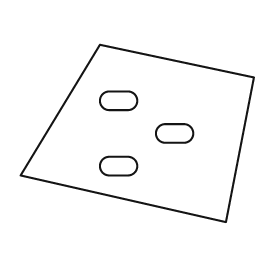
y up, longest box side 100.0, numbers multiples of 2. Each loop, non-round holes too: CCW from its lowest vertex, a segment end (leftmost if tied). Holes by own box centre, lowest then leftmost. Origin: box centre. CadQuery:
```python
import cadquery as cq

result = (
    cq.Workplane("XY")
    .moveTo(38.0, -38.0)
    .lineTo(50.0, 24.0)
    .lineTo(-16.0, 38.0)
    .lineTo(-50.0, -18.0)
    .close()
    .moveTo(-12.0, -18.0)
    .lineTo(-4.0, -18.0)
    .threePointArc((0.0, -14.0), (-4.0, -10.0))
    .lineTo(-12.0, -10.0)
    .threePointArc((-16.0, -14.0), (-12.0, -18.0))
    .close()
    .moveTo(12.0, -4.0)
    .lineTo(20.0, -4.0)
    .threePointArc((24.0, 0.0), (20.0, 4.0))
    .lineTo(12.0, 4.0)
    .threePointArc((8.0, 0.0), (12.0, -4.0))
    .close()
    .moveTo(-12.0, 10.0)
    .lineTo(-4.0, 10.0)
    .threePointArc((0.0, 14.0), (-4.0, 18.0))
    .lineTo(-12.0, 18.0)
    .threePointArc((-16.0, 14.0), (-12.0, 10.0))
    .close()
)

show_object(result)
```